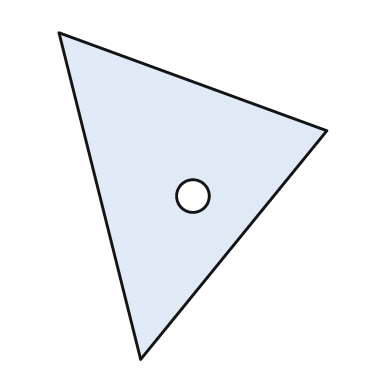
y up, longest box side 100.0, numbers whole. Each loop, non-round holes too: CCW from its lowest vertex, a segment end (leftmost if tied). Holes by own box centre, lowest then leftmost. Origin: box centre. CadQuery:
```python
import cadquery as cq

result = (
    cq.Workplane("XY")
    .moveTo(-16.0, -50.0)
    .lineTo(41.0, 20.0)
    .lineTo(-41.0, 50.0)
    .close()
    .moveTo(0.0, 0.0)
    .circle(5.0)
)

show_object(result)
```